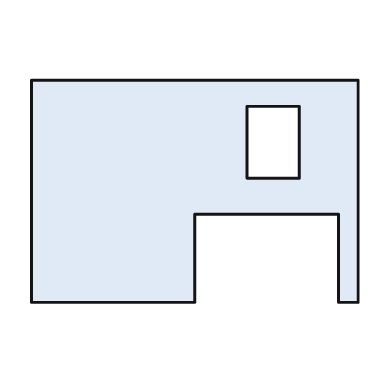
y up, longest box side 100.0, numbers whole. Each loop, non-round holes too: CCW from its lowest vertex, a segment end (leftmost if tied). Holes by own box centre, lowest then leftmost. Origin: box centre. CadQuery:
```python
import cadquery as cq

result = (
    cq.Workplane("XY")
    .moveTo(-50.0, -34.0)
    .lineTo(0.0, -34.0)
    .lineTo(0.0, -7.0)
    .lineTo(44.0, -7.0)
    .lineTo(44.0, -34.0)
    .lineTo(50.0, -34.0)
    .lineTo(50.0, 34.0)
    .lineTo(-50.0, 34.0)
    .close()
    .moveTo(16.0, 4.0)
    .lineTo(32.0, 4.0)
    .lineTo(32.0, 26.0)
    .lineTo(16.0, 26.0)
    .close()
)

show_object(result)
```